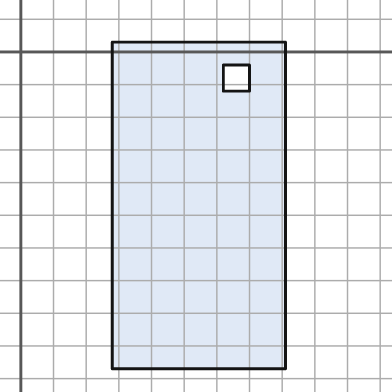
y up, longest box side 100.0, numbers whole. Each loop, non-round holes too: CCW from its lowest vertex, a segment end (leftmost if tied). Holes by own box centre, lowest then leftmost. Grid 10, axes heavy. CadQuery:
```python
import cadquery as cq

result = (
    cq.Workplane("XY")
    .moveTo(28.0, -97.0)
    .lineTo(81.0, -97.0)
    .lineTo(81.0, 3.0)
    .lineTo(28.0, 3.0)
    .close()
    .moveTo(62.0, -12.0)
    .lineTo(70.0, -12.0)
    .lineTo(70.0, -4.0)
    .lineTo(62.0, -4.0)
    .close()
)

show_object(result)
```